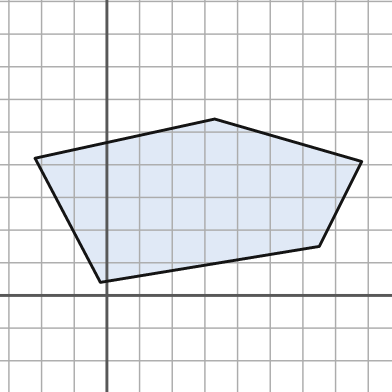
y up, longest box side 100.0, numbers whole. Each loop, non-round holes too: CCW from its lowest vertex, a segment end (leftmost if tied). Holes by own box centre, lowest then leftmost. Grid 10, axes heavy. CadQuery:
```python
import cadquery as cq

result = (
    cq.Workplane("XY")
    .moveTo(-2.0, 4.0)
    .lineTo(65.0, 15.0)
    .lineTo(78.0, 41.0)
    .lineTo(33.0, 54.0)
    .lineTo(-22.0, 42.0)
    .close()
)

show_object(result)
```